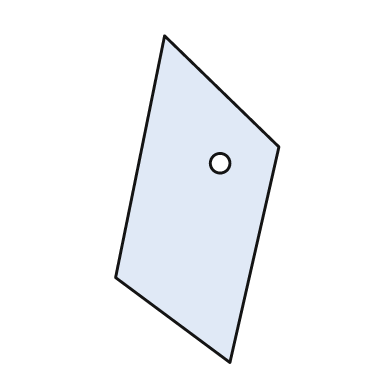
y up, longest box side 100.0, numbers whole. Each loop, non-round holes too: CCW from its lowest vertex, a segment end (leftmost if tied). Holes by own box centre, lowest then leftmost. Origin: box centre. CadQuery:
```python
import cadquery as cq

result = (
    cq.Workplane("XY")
    .moveTo(10.0, -50.0)
    .lineTo(25.0, 16.0)
    .lineTo(-10.0, 50.0)
    .lineTo(-25.0, -24.0)
    .close()
    .moveTo(7.0, 11.0)
    .circle(3.0)
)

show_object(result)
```